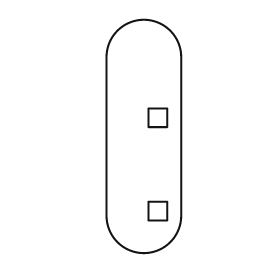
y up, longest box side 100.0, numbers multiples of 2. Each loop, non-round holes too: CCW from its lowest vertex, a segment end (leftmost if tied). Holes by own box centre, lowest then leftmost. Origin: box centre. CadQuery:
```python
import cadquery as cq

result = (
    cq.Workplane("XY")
    .moveTo(-16.0, -34.0)
    .threePointArc((0.0, -50.0), (16.0, -34.0))
    .lineTo(16.0, 34.0)
    .threePointArc((0.0, 50.0), (-16.0, 34.0))
    .close()
    .moveTo(2.0, -36.0)
    .lineTo(10.0, -36.0)
    .lineTo(10.0, -28.0)
    .lineTo(2.0, -28.0)
    .close()
    .moveTo(2.0, 4.0)
    .lineTo(10.0, 4.0)
    .lineTo(10.0, 12.0)
    .lineTo(2.0, 12.0)
    .close()
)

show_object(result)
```